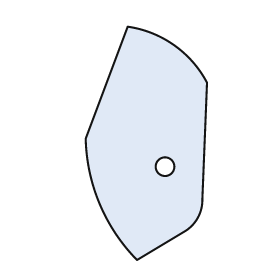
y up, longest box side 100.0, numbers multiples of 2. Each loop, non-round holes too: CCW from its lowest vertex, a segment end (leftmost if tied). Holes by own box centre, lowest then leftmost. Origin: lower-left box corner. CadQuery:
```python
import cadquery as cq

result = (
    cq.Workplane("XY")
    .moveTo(22.0, 0.0)
    .lineTo(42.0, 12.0)
    .threePointArc((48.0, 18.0), (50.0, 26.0))
    .lineTo(52.0, 76.0)
    .threePointArc((38.0, 92.0), (18.0, 100.0))
    .lineTo(0.0, 52.0)
    .threePointArc((6.0, 24.0), (22.0, 0.0))
    .close()
    .moveTo(34.0, 40.0)
    .circle(4.0)
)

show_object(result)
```